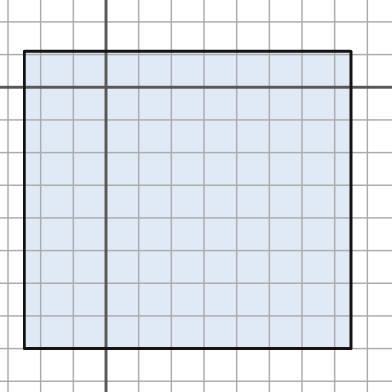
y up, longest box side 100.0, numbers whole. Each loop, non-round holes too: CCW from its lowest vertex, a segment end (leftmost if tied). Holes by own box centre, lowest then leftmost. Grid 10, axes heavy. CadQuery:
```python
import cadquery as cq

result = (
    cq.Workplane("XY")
    .moveTo(-25.0, -80.0)
    .lineTo(75.0, -80.0)
    .lineTo(75.0, 11.0)
    .lineTo(-25.0, 11.0)
    .close()
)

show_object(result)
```